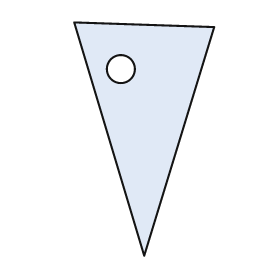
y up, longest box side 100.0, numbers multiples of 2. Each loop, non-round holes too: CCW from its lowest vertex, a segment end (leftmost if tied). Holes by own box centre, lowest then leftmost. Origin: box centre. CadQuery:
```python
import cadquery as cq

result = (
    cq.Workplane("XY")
    .moveTo(0.0, -50.0)
    .lineTo(30.0, 48.0)
    .lineTo(-30.0, 50.0)
    .close()
    .moveTo(-10.0, 30.0)
    .circle(6.0)
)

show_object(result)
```